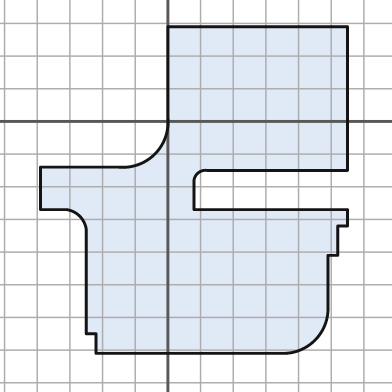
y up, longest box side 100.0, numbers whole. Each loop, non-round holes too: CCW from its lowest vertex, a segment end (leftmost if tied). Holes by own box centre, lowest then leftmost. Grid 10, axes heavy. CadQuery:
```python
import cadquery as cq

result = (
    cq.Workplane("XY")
    .moveTo(-22.0, -71.0)
    .lineTo(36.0, -71.0)
    .threePointArc((45.0, -67.0), (49.0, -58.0))
    .lineTo(49.0, -41.0)
    .lineTo(52.0, -41.0)
    .lineTo(52.0, -32.0)
    .lineTo(55.0, -32.0)
    .lineTo(55.0, -27.0)
    .lineTo(8.0, -27.0)
    .lineTo(8.0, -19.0)
    .threePointArc((9.0, -16.0), (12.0, -15.0))
    .lineTo(55.0, -15.0)
    .lineTo(55.0, 29.0)
    .lineTo(0.0, 29.0)
    .lineTo(0.0, 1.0)
    .threePointArc((-4.0, -10.0), (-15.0, -14.0))
    .lineTo(-39.0, -14.0)
    .lineTo(-39.0, -27.0)
    .lineTo(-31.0, -27.0)
    .threePointArc((-27.0, -29.0), (-25.0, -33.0))
    .lineTo(-25.0, -65.0)
    .lineTo(-22.0, -65.0)
    .close()
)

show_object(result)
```